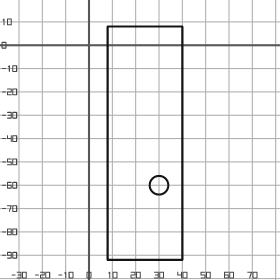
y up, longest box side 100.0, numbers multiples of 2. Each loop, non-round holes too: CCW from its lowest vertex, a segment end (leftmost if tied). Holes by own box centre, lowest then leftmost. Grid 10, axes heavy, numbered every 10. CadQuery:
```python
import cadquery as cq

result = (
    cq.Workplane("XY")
    .moveTo(8.0, -92.0)
    .lineTo(40.0, -92.0)
    .lineTo(40.0, 8.0)
    .lineTo(8.0, 8.0)
    .close()
    .moveTo(30.0, -60.0)
    .circle(4.0)
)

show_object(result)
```